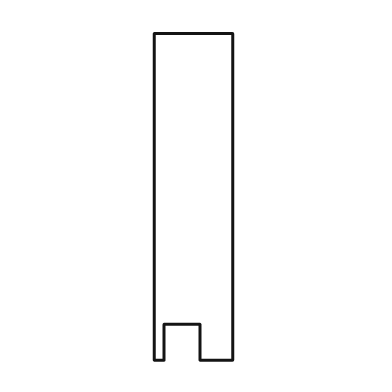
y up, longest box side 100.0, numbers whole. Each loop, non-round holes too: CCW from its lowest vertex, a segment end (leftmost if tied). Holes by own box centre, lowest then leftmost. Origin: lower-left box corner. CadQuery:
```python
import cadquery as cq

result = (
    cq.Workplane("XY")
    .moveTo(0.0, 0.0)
    .lineTo(3.0, 0.0)
    .lineTo(3.0, 11.0)
    .lineTo(14.0, 11.0)
    .lineTo(14.0, 0.0)
    .lineTo(24.0, 0.0)
    .lineTo(24.0, 100.0)
    .lineTo(0.0, 100.0)
    .close()
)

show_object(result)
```